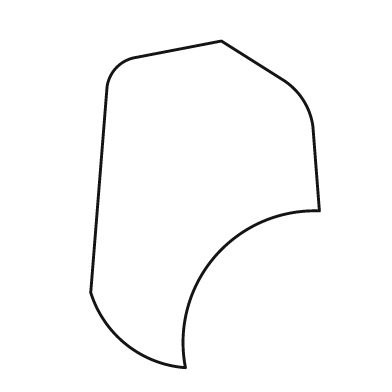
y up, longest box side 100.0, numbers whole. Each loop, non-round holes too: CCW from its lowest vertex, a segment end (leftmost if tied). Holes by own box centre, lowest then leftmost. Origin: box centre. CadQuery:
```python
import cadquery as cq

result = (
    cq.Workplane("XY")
    .moveTo(-6.0, -50.0)
    .threePointArc((3.0, -16.0), (35.0, -2.0))
    .lineTo(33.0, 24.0)
    .threePointArc((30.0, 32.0), (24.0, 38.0))
    .lineTo(5.0, 50.0)
    .lineTo(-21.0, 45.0)
    .threePointArc((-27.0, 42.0), (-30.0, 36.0))
    .lineTo(-35.0, -27.0)
    .threePointArc((-24.0, -43.0), (-6.0, -50.0))
    .close()
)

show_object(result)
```